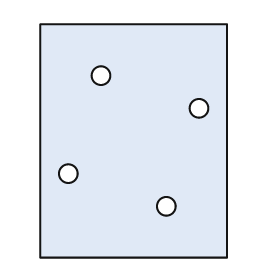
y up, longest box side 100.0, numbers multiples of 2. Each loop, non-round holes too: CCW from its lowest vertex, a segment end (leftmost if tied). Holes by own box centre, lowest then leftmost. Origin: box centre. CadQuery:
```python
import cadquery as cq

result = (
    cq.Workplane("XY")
    .moveTo(-40.0, -50.0)
    .lineTo(40.0, -50.0)
    .lineTo(40.0, 50.0)
    .lineTo(-40.0, 50.0)
    .close()
    .moveTo(14.0, -28.0)
    .circle(4.0)
    .moveTo(-28.0, -14.0)
    .circle(4.0)
    .moveTo(28.0, 14.0)
    .circle(4.0)
    .moveTo(-14.0, 28.0)
    .circle(4.0)
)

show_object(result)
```